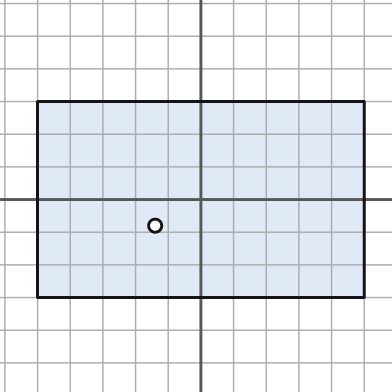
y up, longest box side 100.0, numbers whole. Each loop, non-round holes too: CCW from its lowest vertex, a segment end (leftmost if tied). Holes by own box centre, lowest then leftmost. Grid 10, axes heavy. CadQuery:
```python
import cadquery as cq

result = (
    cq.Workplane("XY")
    .moveTo(-50.0, -30.0)
    .lineTo(50.0, -30.0)
    .lineTo(50.0, 30.0)
    .lineTo(-50.0, 30.0)
    .close()
    .moveTo(-14.0, -8.0)
    .circle(2.0)
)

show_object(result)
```